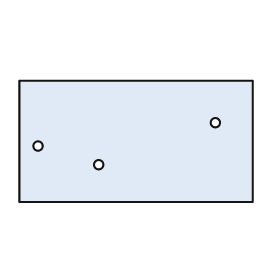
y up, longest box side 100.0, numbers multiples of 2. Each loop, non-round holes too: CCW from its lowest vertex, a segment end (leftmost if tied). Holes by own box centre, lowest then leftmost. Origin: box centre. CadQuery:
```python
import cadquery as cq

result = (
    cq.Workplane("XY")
    .moveTo(-50.0, -26.0)
    .lineTo(50.0, -26.0)
    .lineTo(50.0, 26.0)
    .lineTo(-50.0, 26.0)
    .close()
    .moveTo(-16.0, -10.0)
    .circle(2.0)
    .moveTo(-42.0, -2.0)
    .circle(2.0)
    .moveTo(34.0, 8.0)
    .circle(2.0)
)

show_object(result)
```